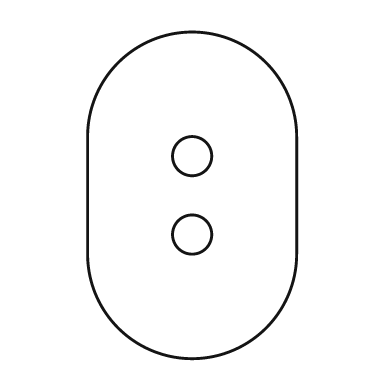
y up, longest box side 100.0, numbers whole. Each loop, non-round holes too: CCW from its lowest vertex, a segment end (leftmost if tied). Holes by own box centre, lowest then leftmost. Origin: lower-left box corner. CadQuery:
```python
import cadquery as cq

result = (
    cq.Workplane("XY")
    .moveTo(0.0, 32.0)
    .threePointArc((32.0, 0.0), (64.0, 32.0))
    .lineTo(64.0, 68.0)
    .threePointArc((32.0, 100.0), (0.0, 68.0))
    .close()
    .moveTo(32.0, 38.0)
    .circle(6.0)
    .moveTo(32.0, 62.0)
    .circle(6.0)
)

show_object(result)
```